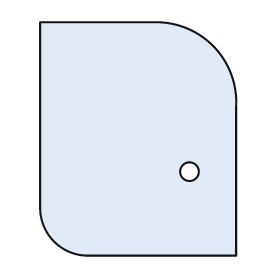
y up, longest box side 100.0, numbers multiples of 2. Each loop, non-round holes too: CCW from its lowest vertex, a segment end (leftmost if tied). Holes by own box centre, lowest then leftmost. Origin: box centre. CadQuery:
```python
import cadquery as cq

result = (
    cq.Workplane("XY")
    .moveTo(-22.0, -50.0)
    .lineTo(42.0, -50.0)
    .lineTo(42.0, 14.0)
    .threePointArc((32.0, 40.0), (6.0, 50.0))
    .lineTo(-42.0, 50.0)
    .lineTo(-42.0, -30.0)
    .threePointArc((-36.0, -44.0), (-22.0, -50.0))
    .close()
    .moveTo(22.0, -14.0)
    .circle(4.0)
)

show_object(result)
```